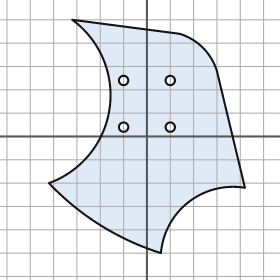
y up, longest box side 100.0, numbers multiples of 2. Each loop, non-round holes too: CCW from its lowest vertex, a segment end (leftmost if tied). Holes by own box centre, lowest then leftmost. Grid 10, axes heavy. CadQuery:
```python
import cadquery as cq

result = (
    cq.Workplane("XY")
    .moveTo(6.0, -50.0)
    .threePointArc((18.0, -28.0), (42.0, -22.0))
    .lineTo(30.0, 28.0)
    .threePointArc((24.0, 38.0), (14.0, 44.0))
    .lineTo(-32.0, 50.0)
    .threePointArc((-16.0, 12.0), (-42.0, -20.0))
    .threePointArc((-20.0, -38.0), (6.0, -50.0))
    .close()
    .moveTo(-10.0, 4.0)
    .circle(2.0)
    .moveTo(10.0, 4.0)
    .circle(2.0)
    .moveTo(-10.0, 24.0)
    .circle(2.0)
    .moveTo(10.0, 24.0)
    .circle(2.0)
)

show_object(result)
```